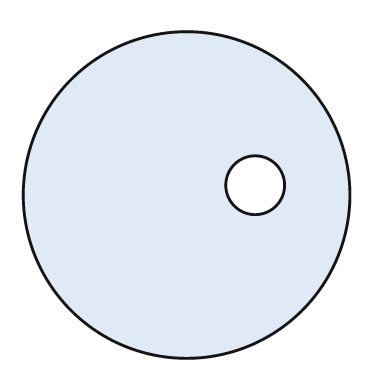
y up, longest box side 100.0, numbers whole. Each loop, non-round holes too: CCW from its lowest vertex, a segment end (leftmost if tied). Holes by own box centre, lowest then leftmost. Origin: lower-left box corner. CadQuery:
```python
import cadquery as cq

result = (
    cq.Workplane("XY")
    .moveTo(50.0, 50.0)
    .circle(50.0)
    .moveTo(71.0, 53.0)
    .circle(9.0)
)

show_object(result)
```